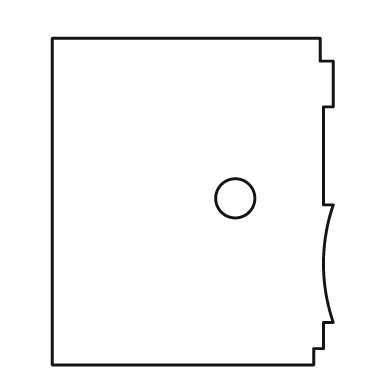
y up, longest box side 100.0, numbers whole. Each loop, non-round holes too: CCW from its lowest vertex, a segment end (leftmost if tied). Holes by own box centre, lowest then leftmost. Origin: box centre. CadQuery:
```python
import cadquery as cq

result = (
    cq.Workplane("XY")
    .moveTo(-43.0, -50.0)
    .lineTo(37.0, -50.0)
    .lineTo(37.0, -45.0)
    .lineTo(40.0, -45.0)
    .lineTo(40.0, -37.0)
    .lineTo(43.0, -37.0)
    .threePointArc((40.0, -19.0), (43.0, -1.0))
    .lineTo(40.0, -1.0)
    .lineTo(40.0, 29.0)
    .lineTo(43.0, 29.0)
    .lineTo(43.0, 43.0)
    .lineTo(39.0, 43.0)
    .lineTo(39.0, 50.0)
    .lineTo(-43.0, 50.0)
    .close()
    .moveTo(13.0, 1.0)
    .circle(6.0)
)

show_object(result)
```